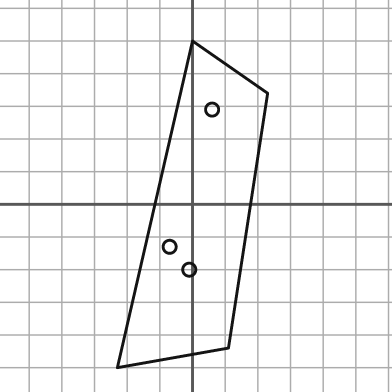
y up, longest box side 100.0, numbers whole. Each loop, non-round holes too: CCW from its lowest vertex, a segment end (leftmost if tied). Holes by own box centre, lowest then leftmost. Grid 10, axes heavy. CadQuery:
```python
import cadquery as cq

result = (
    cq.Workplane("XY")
    .moveTo(-23.0, -50.0)
    .lineTo(11.0, -44.0)
    .lineTo(23.0, 34.0)
    .lineTo(0.0, 50.0)
    .close()
    .moveTo(-1.0, -20.0)
    .circle(2.0)
    .moveTo(-7.0, -13.0)
    .circle(2.0)
    .moveTo(6.0, 29.0)
    .circle(2.0)
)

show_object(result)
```